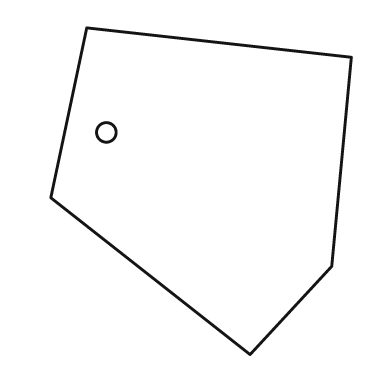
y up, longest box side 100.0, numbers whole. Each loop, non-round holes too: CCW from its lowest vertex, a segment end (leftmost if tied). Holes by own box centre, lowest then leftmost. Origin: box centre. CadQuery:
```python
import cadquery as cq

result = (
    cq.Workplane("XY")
    .moveTo(15.0, -50.0)
    .lineTo(40.0, -23.0)
    .lineTo(46.0, 41.0)
    .lineTo(-35.0, 50.0)
    .lineTo(-46.0, -2.0)
    .close()
    .moveTo(-29.0, 18.0)
    .circle(3.0)
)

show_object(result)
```